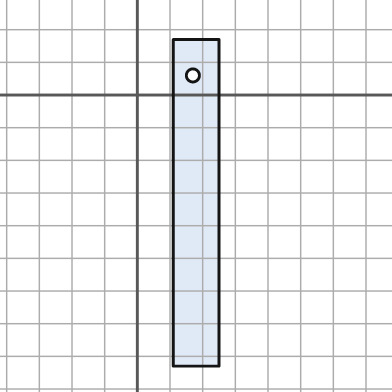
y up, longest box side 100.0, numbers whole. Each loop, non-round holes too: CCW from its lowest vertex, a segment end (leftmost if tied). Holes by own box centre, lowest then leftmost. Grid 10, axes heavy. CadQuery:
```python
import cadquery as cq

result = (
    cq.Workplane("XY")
    .moveTo(11.0, -83.0)
    .lineTo(25.0, -83.0)
    .lineTo(25.0, 17.0)
    .lineTo(11.0, 17.0)
    .close()
    .moveTo(17.0, 6.0)
    .circle(2.0)
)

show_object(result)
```